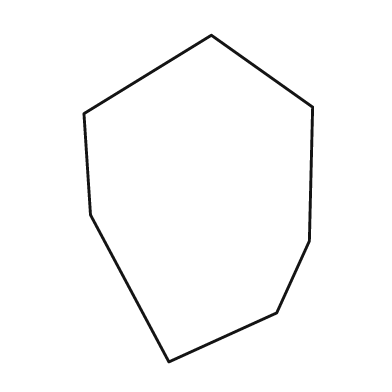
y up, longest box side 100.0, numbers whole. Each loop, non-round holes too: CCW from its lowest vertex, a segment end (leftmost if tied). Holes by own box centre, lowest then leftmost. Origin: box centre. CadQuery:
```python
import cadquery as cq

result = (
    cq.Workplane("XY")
    .moveTo(-9.0, -50.0)
    .lineTo(24.0, -35.0)
    .lineTo(34.0, -13.0)
    .lineTo(35.0, 28.0)
    .lineTo(4.0, 50.0)
    .lineTo(-35.0, 26.0)
    .lineTo(-33.0, -5.0)
    .close()
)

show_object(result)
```